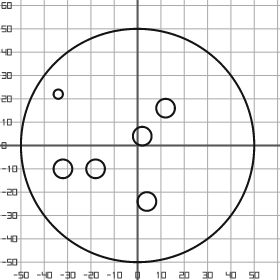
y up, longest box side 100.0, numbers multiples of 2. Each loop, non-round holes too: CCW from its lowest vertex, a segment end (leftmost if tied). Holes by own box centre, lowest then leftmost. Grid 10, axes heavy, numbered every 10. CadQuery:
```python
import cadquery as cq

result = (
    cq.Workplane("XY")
    .moveTo(0.0, 0.0)
    .circle(50.0)
    .moveTo(4.0, -24.0)
    .circle(4.0)
    .moveTo(-32.0, -10.0)
    .circle(4.0)
    .moveTo(-18.0, -10.0)
    .circle(4.0)
    .moveTo(2.0, 4.0)
    .circle(4.0)
    .moveTo(12.0, 16.0)
    .circle(4.0)
    .moveTo(-34.0, 22.0)
    .circle(2.0)
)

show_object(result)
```